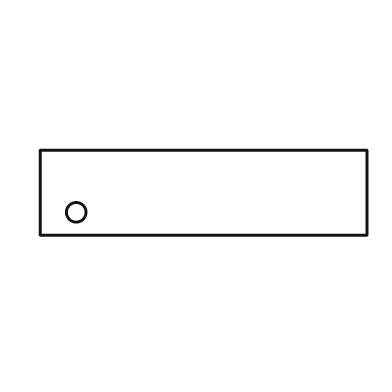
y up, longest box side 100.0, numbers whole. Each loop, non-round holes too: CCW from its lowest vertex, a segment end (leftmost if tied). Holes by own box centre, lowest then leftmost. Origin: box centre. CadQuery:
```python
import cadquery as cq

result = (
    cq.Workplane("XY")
    .moveTo(-50.0, -13.0)
    .lineTo(50.0, -13.0)
    .lineTo(50.0, 13.0)
    .lineTo(-50.0, 13.0)
    .close()
    .moveTo(-39.0, -6.0)
    .circle(3.0)
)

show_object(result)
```